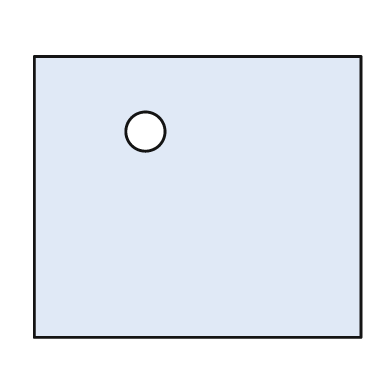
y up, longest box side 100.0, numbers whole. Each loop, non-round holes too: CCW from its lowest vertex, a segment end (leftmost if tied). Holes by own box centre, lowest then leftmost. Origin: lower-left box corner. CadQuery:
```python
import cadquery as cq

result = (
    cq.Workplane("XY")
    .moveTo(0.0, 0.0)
    .lineTo(100.0, 0.0)
    .lineTo(100.0, 86.0)
    .lineTo(0.0, 86.0)
    .close()
    .moveTo(34.0, 63.0)
    .circle(6.0)
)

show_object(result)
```